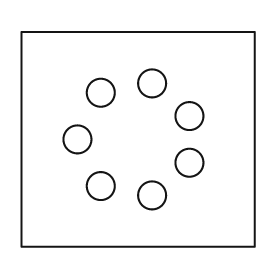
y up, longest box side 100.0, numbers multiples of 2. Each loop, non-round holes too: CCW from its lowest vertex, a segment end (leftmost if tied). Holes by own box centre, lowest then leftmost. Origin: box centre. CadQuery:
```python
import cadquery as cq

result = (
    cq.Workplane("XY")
    .moveTo(-50.0, -46.0)
    .lineTo(50.0, -46.0)
    .lineTo(50.0, 46.0)
    .lineTo(-50.0, 46.0)
    .close()
    .moveTo(6.0, -24.0)
    .circle(6.0)
    .moveTo(-16.0, -20.0)
    .circle(6.0)
    .moveTo(22.0, -10.0)
    .circle(6.0)
    .moveTo(-26.0, 0.0)
    .circle(6.0)
    .moveTo(22.0, 10.0)
    .circle(6.0)
    .moveTo(-16.0, 20.0)
    .circle(6.0)
    .moveTo(6.0, 24.0)
    .circle(6.0)
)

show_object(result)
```